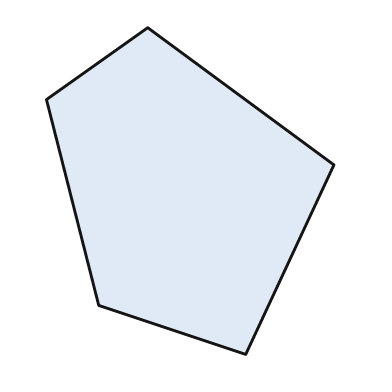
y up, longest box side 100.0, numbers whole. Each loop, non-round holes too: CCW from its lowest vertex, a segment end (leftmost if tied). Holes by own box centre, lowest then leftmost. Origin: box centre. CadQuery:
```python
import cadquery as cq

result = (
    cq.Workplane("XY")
    .moveTo(17.0, -50.0)
    .lineTo(44.0, 8.0)
    .lineTo(-13.0, 50.0)
    .lineTo(-44.0, 28.0)
    .lineTo(-28.0, -35.0)
    .close()
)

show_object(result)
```